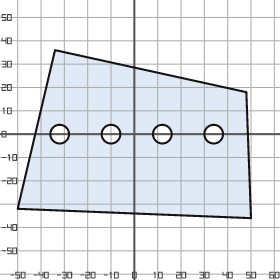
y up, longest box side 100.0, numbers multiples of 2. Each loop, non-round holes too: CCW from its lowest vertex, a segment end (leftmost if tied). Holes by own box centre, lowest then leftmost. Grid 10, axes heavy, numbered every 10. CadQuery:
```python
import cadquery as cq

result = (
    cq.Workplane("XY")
    .moveTo(50.0, -36.0)
    .lineTo(48.0, 18.0)
    .lineTo(-34.0, 36.0)
    .lineTo(-50.0, -32.0)
    .close()
    .moveTo(-32.0, 0.0)
    .circle(4.0)
    .moveTo(-10.0, 0.0)
    .circle(4.0)
    .moveTo(12.0, 0.0)
    .circle(4.0)
    .moveTo(34.0, 0.0)
    .circle(4.0)
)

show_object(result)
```